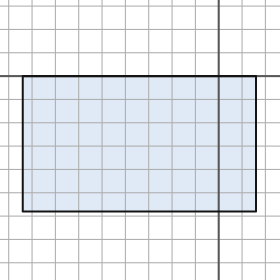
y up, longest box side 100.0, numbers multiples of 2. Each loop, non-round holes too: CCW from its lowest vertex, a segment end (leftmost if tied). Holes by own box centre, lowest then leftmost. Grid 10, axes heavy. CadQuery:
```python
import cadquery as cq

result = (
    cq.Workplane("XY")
    .moveTo(-84.0, -58.0)
    .lineTo(16.0, -58.0)
    .lineTo(16.0, 0.0)
    .lineTo(-84.0, 0.0)
    .close()
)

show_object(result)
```